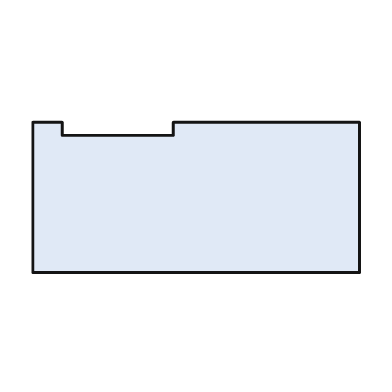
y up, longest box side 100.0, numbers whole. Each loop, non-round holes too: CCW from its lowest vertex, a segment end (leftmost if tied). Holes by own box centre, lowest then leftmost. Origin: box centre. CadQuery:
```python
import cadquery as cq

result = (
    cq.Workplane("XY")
    .moveTo(-50.0, -23.0)
    .lineTo(50.0, -23.0)
    .lineTo(50.0, 23.0)
    .lineTo(-7.0, 23.0)
    .lineTo(-7.0, 19.0)
    .lineTo(-41.0, 19.0)
    .lineTo(-41.0, 23.0)
    .lineTo(-50.0, 23.0)
    .close()
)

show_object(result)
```